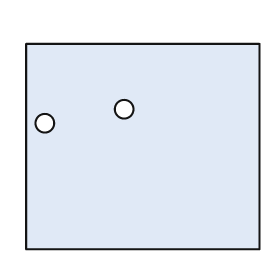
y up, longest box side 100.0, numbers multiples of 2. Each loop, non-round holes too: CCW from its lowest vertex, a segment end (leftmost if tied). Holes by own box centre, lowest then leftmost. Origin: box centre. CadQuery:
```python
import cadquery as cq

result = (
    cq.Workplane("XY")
    .moveTo(-50.0, -44.0)
    .lineTo(50.0, -44.0)
    .lineTo(50.0, 44.0)
    .lineTo(-50.0, 44.0)
    .close()
    .moveTo(-42.0, 10.0)
    .circle(4.0)
    .moveTo(-8.0, 16.0)
    .circle(4.0)
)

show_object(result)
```